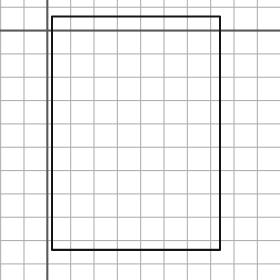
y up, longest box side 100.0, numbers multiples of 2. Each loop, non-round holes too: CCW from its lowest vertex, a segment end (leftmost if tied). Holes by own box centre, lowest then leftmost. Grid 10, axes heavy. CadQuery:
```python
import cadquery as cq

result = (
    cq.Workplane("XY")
    .moveTo(2.0, -94.0)
    .lineTo(74.0, -94.0)
    .lineTo(74.0, 6.0)
    .lineTo(2.0, 6.0)
    .close()
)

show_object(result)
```